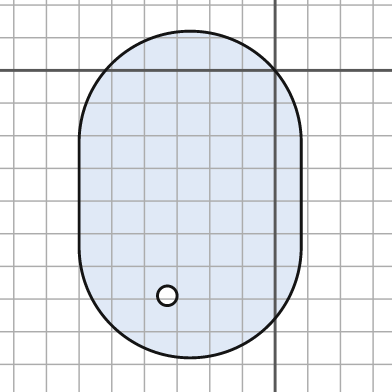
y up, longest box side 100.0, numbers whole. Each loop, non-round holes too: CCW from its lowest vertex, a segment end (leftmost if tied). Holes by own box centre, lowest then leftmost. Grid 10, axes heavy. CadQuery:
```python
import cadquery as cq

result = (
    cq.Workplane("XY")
    .moveTo(-60.0, -54.0)
    .threePointArc((-26.0, -88.0), (8.0, -54.0))
    .lineTo(8.0, -22.0)
    .threePointArc((-26.0, 12.0), (-60.0, -22.0))
    .close()
    .moveTo(-33.0, -69.0)
    .circle(3.0)
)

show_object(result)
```